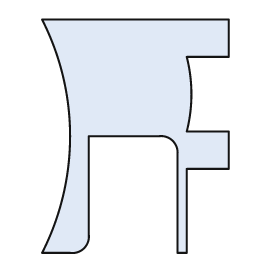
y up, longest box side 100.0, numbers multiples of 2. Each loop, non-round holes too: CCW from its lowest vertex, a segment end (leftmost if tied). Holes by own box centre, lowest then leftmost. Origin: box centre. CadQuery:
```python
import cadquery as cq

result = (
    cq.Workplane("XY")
    .moveTo(-40.0, -50.0)
    .lineTo(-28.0, -50.0)
    .threePointArc((-22.0, -48.0), (-20.0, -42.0))
    .lineTo(-20.0, 0.0)
    .lineTo(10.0, 0.0)
    .threePointArc((16.0, -2.0), (18.0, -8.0))
    .lineTo(18.0, -50.0)
    .lineTo(22.0, -50.0)
    .lineTo(22.0, -14.0)
    .lineTo(40.0, -14.0)
    .lineTo(40.0, 2.0)
    .lineTo(22.0, 2.0)
    .threePointArc((24.0, 18.0), (22.0, 34.0))
    .lineTo(40.0, 34.0)
    .lineTo(40.0, 50.0)
    .lineTo(-40.0, 50.0)
    .threePointArc((-28.0, 0.0), (-40.0, -50.0))
    .close()
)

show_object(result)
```